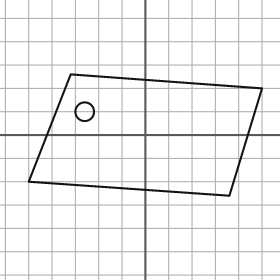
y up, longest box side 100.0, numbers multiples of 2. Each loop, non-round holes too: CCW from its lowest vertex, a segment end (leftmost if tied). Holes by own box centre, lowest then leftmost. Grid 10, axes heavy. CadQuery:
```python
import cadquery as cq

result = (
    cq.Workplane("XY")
    .moveTo(36.0, -26.0)
    .lineTo(50.0, 20.0)
    .lineTo(-32.0, 26.0)
    .lineTo(-50.0, -20.0)
    .close()
    .moveTo(-26.0, 10.0)
    .circle(4.0)
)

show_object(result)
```